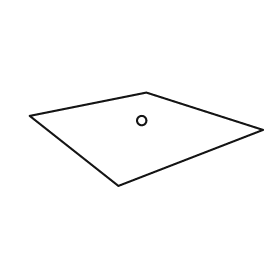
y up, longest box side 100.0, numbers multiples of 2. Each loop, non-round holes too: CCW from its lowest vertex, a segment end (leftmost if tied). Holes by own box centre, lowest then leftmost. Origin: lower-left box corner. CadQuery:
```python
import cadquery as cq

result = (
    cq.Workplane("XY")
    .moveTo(38.0, 0.0)
    .lineTo(100.0, 24.0)
    .lineTo(50.0, 40.0)
    .lineTo(0.0, 30.0)
    .close()
    .moveTo(48.0, 28.0)
    .circle(2.0)
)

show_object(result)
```